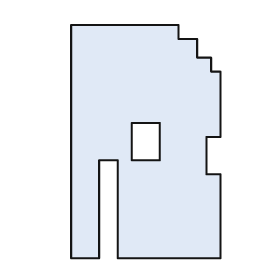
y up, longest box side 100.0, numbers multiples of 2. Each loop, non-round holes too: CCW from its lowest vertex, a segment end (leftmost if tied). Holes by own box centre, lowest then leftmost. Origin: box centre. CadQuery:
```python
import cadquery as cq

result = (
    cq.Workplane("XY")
    .moveTo(-32.0, -50.0)
    .lineTo(-20.0, -50.0)
    .lineTo(-20.0, -8.0)
    .lineTo(-12.0, -8.0)
    .lineTo(-12.0, -50.0)
    .lineTo(32.0, -50.0)
    .lineTo(32.0, -14.0)
    .lineTo(26.0, -14.0)
    .lineTo(26.0, 2.0)
    .lineTo(32.0, 2.0)
    .lineTo(32.0, 30.0)
    .lineTo(28.0, 30.0)
    .lineTo(28.0, 36.0)
    .lineTo(22.0, 36.0)
    .lineTo(22.0, 44.0)
    .lineTo(14.0, 44.0)
    .lineTo(14.0, 50.0)
    .lineTo(-32.0, 50.0)
    .close()
    .moveTo(-6.0, -8.0)
    .lineTo(6.0, -8.0)
    .lineTo(6.0, 8.0)
    .lineTo(-6.0, 8.0)
    .close()
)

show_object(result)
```